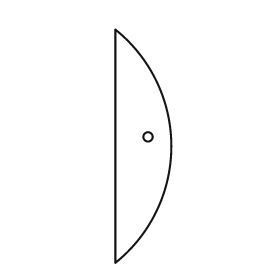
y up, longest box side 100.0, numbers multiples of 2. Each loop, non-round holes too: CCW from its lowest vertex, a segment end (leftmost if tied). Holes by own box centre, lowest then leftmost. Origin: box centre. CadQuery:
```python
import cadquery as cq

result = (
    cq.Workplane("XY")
    .moveTo(-12.0, -50.0)
    .threePointArc((12.0, 0.0), (-12.0, 50.0))
    .close()
    .moveTo(2.0, 4.0)
    .circle(2.0)
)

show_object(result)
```